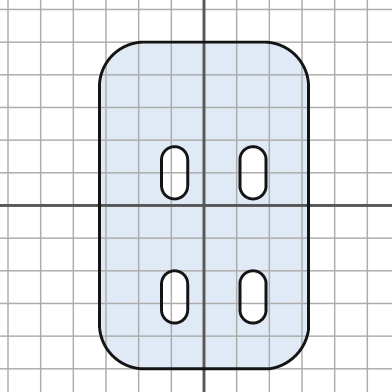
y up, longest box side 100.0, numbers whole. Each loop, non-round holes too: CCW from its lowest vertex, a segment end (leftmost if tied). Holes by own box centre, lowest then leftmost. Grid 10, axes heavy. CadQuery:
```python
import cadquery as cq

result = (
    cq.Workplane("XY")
    .moveTo(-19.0, -50.0)
    .lineTo(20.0, -50.0)
    .threePointArc((28.0, -46.0), (32.0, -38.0))
    .lineTo(32.0, 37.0)
    .threePointArc((28.0, 46.0), (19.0, 50.0))
    .lineTo(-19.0, 50.0)
    .threePointArc((-28.0, 46.0), (-32.0, 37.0))
    .lineTo(-32.0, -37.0)
    .threePointArc((-28.0, -46.0), (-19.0, -50.0))
    .close()
    .moveTo(-13.0, -32.0)
    .threePointArc((-9.0, -36.0), (-5.0, -32.0))
    .lineTo(-5.0, -24.0)
    .threePointArc((-9.0, -20.0), (-13.0, -24.0))
    .close()
    .moveTo(11.0, -32.0)
    .threePointArc((15.0, -36.0), (19.0, -32.0))
    .lineTo(19.0, -24.0)
    .threePointArc((15.0, -20.0), (11.0, -24.0))
    .close()
    .moveTo(-13.0, 6.0)
    .threePointArc((-9.0, 2.0), (-5.0, 6.0))
    .lineTo(-5.0, 14.0)
    .threePointArc((-9.0, 18.0), (-13.0, 14.0))
    .close()
    .moveTo(11.0, 6.0)
    .threePointArc((15.0, 2.0), (19.0, 6.0))
    .lineTo(19.0, 14.0)
    .threePointArc((15.0, 18.0), (11.0, 14.0))
    .close()
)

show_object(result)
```